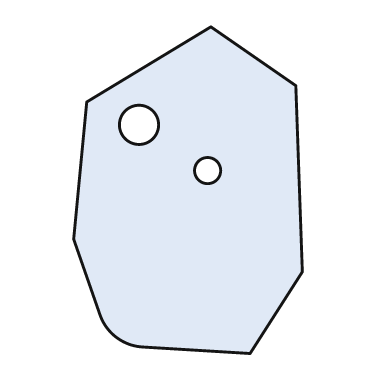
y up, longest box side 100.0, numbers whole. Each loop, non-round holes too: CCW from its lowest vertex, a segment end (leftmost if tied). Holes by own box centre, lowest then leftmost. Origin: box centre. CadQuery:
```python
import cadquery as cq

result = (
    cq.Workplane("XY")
    .moveTo(19.0, -50.0)
    .lineTo(35.0, -25.0)
    .lineTo(33.0, 32.0)
    .lineTo(7.0, 50.0)
    .lineTo(-31.0, 27.0)
    .lineTo(-35.0, -15.0)
    .lineTo(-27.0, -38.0)
    .threePointArc((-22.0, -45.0), (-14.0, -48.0))
    .close()
    .moveTo(6.0, 6.0)
    .circle(4.0)
    .moveTo(-15.0, 20.0)
    .circle(6.0)
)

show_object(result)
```